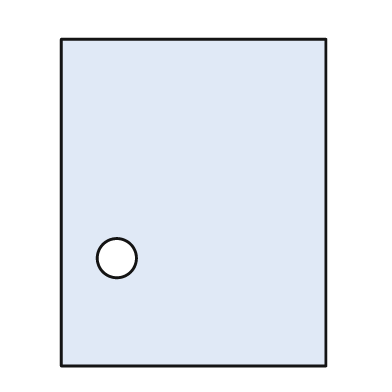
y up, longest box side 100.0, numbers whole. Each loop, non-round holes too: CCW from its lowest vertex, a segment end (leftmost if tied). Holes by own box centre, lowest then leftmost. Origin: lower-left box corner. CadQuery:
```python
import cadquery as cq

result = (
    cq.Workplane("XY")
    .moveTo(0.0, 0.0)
    .lineTo(81.0, 0.0)
    .lineTo(81.0, 100.0)
    .lineTo(0.0, 100.0)
    .close()
    .moveTo(17.0, 33.0)
    .circle(6.0)
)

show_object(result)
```